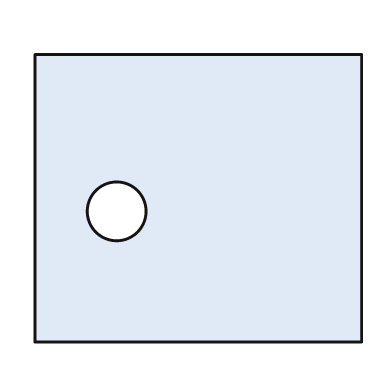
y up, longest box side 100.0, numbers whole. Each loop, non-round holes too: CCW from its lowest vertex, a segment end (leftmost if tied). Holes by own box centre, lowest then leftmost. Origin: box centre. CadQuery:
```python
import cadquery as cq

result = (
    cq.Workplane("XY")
    .moveTo(-50.0, -44.0)
    .lineTo(50.0, -44.0)
    .lineTo(50.0, 44.0)
    .lineTo(-50.0, 44.0)
    .close()
    .moveTo(-25.0, -4.0)
    .circle(9.0)
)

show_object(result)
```